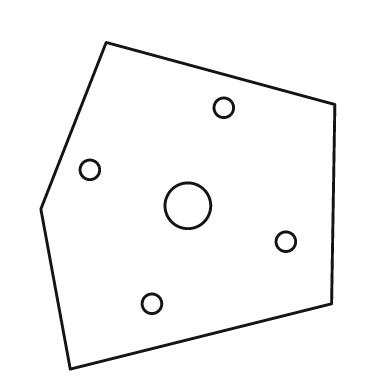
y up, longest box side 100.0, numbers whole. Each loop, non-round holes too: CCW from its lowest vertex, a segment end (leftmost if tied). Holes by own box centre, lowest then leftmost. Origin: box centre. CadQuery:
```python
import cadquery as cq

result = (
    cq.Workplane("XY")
    .moveTo(-36.0, -50.0)
    .lineTo(44.0, -30.0)
    .lineTo(45.0, 31.0)
    .lineTo(-25.0, 50.0)
    .lineTo(-45.0, -1.0)
    .close()
    .moveTo(-11.0, -30.0)
    .circle(3.0)
    .moveTo(30.0, -11.0)
    .circle(3.0)
    .moveTo(0.0, 0.0)
    .circle(7.0)
    .moveTo(-30.0, 11.0)
    .circle(3.0)
    .moveTo(11.0, 30.0)
    .circle(3.0)
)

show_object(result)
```